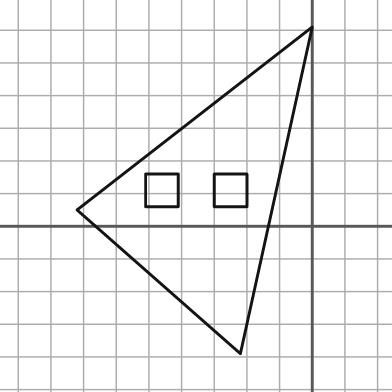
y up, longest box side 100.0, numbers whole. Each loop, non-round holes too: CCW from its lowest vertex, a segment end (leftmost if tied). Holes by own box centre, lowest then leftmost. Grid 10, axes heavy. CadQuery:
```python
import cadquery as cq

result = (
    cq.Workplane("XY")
    .moveTo(-22.0, -39.0)
    .lineTo(0.0, 61.0)
    .lineTo(-72.0, 5.0)
    .close()
    .moveTo(-51.0, 6.0)
    .lineTo(-41.0, 6.0)
    .lineTo(-41.0, 16.0)
    .lineTo(-51.0, 16.0)
    .close()
    .moveTo(-30.0, 6.0)
    .lineTo(-20.0, 6.0)
    .lineTo(-20.0, 16.0)
    .lineTo(-30.0, 16.0)
    .close()
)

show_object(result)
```